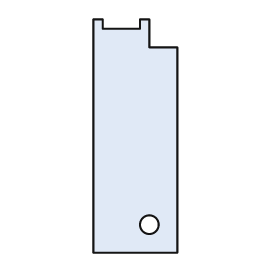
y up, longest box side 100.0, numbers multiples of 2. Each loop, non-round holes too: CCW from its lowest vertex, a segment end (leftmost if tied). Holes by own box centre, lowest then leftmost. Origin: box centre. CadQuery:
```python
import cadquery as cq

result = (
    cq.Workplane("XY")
    .moveTo(-18.0, -50.0)
    .lineTo(18.0, -50.0)
    .lineTo(18.0, 38.0)
    .lineTo(6.0, 38.0)
    .lineTo(6.0, 50.0)
    .lineTo(2.0, 50.0)
    .lineTo(2.0, 46.0)
    .lineTo(-14.0, 46.0)
    .lineTo(-14.0, 50.0)
    .lineTo(-18.0, 50.0)
    .close()
    .moveTo(6.0, -38.0)
    .circle(4.0)
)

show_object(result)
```